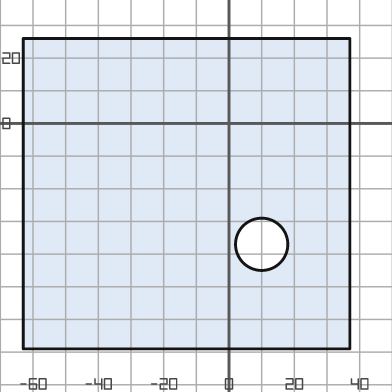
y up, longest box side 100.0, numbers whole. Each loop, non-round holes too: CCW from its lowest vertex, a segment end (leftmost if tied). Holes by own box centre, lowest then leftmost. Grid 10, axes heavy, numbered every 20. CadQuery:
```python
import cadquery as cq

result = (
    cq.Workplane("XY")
    .moveTo(-63.0, -69.0)
    .lineTo(37.0, -69.0)
    .lineTo(37.0, 26.0)
    .lineTo(-63.0, 26.0)
    .close()
    .moveTo(10.0, -37.0)
    .circle(8.0)
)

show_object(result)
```